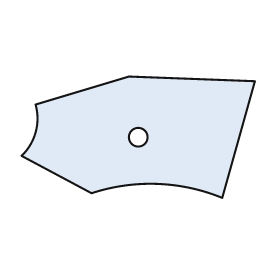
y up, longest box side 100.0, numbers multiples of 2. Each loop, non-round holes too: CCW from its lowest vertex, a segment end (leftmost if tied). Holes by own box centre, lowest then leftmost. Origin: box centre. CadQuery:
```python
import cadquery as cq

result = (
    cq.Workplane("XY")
    .moveTo(36.0, -26.0)
    .lineTo(50.0, 24.0)
    .lineTo(-4.0, 26.0)
    .lineTo(-44.0, 14.0)
    .threePointArc((-44.0, 2.0), (-50.0, -8.0))
    .lineTo(-20.0, -24.0)
    .threePointArc((8.0, -20.0), (36.0, -26.0))
    .close()
    .moveTo(0.0, 0.0)
    .circle(4.0)
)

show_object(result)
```